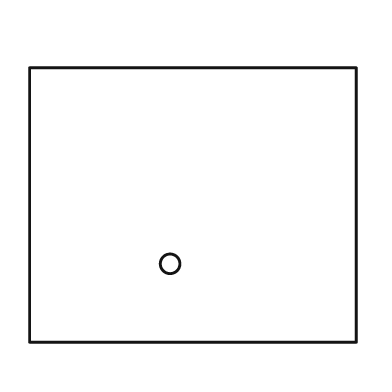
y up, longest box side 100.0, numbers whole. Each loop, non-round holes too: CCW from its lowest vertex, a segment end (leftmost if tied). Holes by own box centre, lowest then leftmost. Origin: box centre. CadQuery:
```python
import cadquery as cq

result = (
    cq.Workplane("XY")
    .moveTo(-50.0, -42.0)
    .lineTo(50.0, -42.0)
    .lineTo(50.0, 42.0)
    .lineTo(-50.0, 42.0)
    .close()
    .moveTo(-7.0, -18.0)
    .circle(3.0)
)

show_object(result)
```